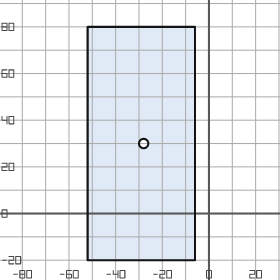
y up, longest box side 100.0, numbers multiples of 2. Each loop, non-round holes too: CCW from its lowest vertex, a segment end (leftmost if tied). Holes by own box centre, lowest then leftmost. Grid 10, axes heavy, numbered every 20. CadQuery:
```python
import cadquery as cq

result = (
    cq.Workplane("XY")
    .moveTo(-52.0, -20.0)
    .lineTo(-6.0, -20.0)
    .lineTo(-6.0, 80.0)
    .lineTo(-52.0, 80.0)
    .close()
    .moveTo(-28.0, 30.0)
    .circle(2.0)
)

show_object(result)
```